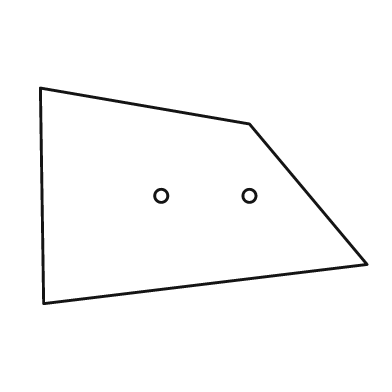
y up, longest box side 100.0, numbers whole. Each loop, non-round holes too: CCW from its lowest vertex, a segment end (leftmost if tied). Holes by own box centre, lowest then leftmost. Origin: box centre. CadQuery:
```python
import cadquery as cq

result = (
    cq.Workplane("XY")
    .moveTo(-49.0, -33.0)
    .lineTo(50.0, -21.0)
    .lineTo(14.0, 22.0)
    .lineTo(-50.0, 33.0)
    .close()
    .moveTo(-13.0, 0.0)
    .circle(2.0)
    .moveTo(14.0, 0.0)
    .circle(2.0)
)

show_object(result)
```